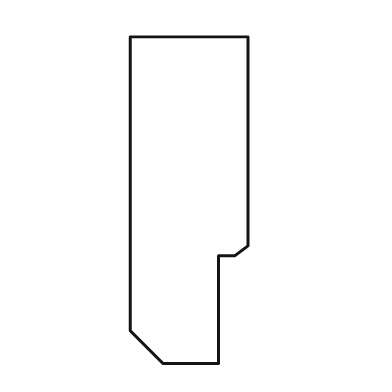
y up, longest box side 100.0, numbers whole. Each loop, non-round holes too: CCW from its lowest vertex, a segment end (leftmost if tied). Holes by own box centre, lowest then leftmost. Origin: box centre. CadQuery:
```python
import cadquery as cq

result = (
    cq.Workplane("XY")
    .moveTo(-8.0, -50.0)
    .lineTo(9.0, -50.0)
    .lineTo(9.0, -17.0)
    .lineTo(14.0, -17.0)
    .lineTo(18.0, -14.0)
    .lineTo(18.0, 50.0)
    .lineTo(-18.0, 50.0)
    .lineTo(-18.0, -40.0)
    .close()
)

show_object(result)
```